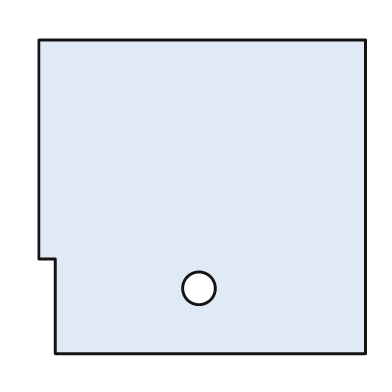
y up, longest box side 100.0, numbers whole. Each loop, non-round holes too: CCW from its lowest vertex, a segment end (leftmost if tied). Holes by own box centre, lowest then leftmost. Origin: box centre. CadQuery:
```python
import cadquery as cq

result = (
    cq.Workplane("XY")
    .moveTo(-45.0, -48.0)
    .lineTo(50.0, -48.0)
    .lineTo(50.0, 48.0)
    .lineTo(-50.0, 48.0)
    .lineTo(-50.0, -19.0)
    .lineTo(-45.0, -19.0)
    .close()
    .moveTo(-1.0, -28.0)
    .circle(5.0)
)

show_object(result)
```